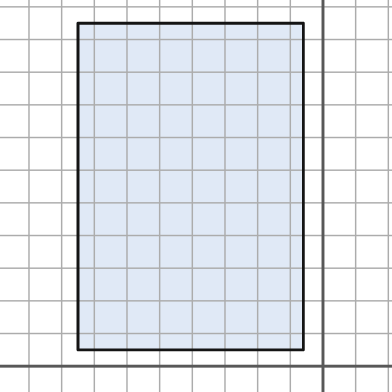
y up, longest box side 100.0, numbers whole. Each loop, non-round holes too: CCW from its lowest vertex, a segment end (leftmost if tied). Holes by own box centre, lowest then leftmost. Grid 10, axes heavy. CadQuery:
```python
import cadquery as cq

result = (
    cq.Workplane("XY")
    .moveTo(-75.0, 5.0)
    .lineTo(-6.0, 5.0)
    .lineTo(-6.0, 105.0)
    .lineTo(-75.0, 105.0)
    .close()
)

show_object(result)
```